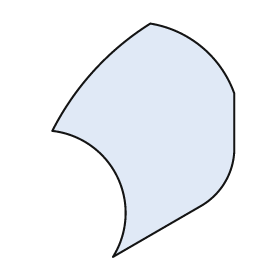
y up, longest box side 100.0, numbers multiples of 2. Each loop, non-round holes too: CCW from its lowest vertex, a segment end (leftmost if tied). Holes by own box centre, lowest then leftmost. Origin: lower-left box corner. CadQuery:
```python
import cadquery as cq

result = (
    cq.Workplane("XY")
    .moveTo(26.0, 0.0)
    .lineTo(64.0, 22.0)
    .threePointArc((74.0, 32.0), (78.0, 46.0))
    .lineTo(78.0, 70.0)
    .threePointArc((64.0, 90.0), (42.0, 100.0))
    .threePointArc((18.0, 80.0), (0.0, 54.0))
    .threePointArc((28.0, 34.0), (26.0, 0.0))
    .close()
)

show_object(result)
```